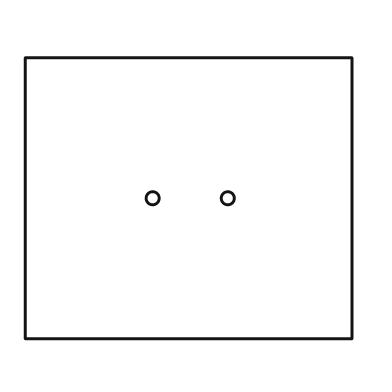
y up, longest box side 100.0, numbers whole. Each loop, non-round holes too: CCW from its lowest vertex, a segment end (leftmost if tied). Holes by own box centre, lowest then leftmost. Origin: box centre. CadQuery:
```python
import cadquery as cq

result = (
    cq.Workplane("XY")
    .moveTo(-50.0, -43.0)
    .lineTo(50.0, -43.0)
    .lineTo(50.0, 43.0)
    .lineTo(-50.0, 43.0)
    .close()
    .moveTo(-11.0, 0.0)
    .circle(2.0)
    .moveTo(12.0, 0.0)
    .circle(2.0)
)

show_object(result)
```